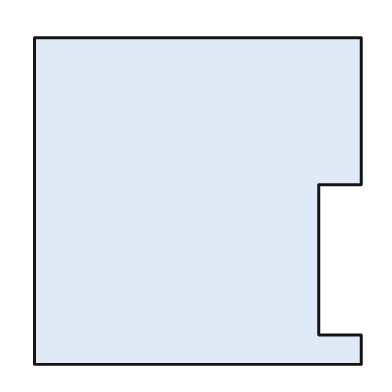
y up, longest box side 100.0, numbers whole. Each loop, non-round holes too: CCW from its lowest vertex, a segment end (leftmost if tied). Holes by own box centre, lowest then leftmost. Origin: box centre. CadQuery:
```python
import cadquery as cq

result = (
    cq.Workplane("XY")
    .moveTo(-50.0, -50.0)
    .lineTo(50.0, -50.0)
    .lineTo(50.0, -41.0)
    .lineTo(37.0, -41.0)
    .lineTo(37.0, 5.0)
    .lineTo(50.0, 5.0)
    .lineTo(50.0, 50.0)
    .lineTo(-50.0, 50.0)
    .close()
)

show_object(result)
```